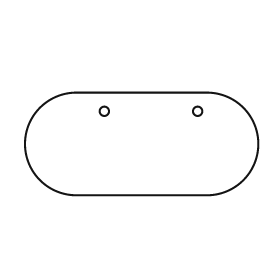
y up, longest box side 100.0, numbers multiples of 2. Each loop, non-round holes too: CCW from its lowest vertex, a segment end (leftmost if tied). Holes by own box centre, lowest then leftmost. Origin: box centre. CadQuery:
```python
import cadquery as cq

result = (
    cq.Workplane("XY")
    .moveTo(-28.0, -22.0)
    .lineTo(28.0, -22.0)
    .threePointArc((50.0, 0.0), (28.0, 22.0))
    .lineTo(-28.0, 22.0)
    .threePointArc((-50.0, 0.0), (-28.0, -22.0))
    .close()
    .moveTo(-16.0, 14.0)
    .circle(2.0)
    .moveTo(24.0, 14.0)
    .circle(2.0)
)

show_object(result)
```